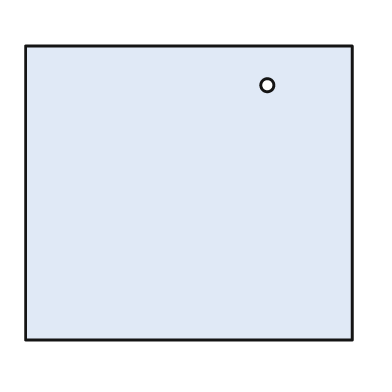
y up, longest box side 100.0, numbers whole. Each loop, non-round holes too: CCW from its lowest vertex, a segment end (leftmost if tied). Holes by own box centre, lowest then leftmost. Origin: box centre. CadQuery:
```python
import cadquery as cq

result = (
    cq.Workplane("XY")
    .moveTo(-50.0, -45.0)
    .lineTo(50.0, -45.0)
    .lineTo(50.0, 45.0)
    .lineTo(-50.0, 45.0)
    .close()
    .moveTo(24.0, 33.0)
    .circle(2.0)
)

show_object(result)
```